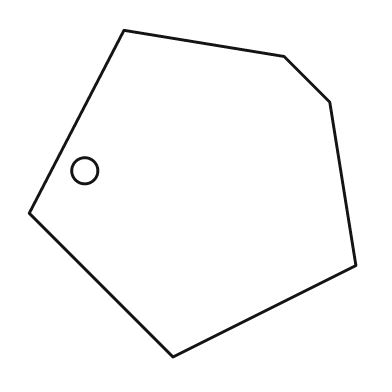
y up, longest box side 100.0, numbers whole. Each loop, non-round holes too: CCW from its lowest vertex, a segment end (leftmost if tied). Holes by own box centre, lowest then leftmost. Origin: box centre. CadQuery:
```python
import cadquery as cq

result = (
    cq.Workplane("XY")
    .moveTo(-6.0, -50.0)
    .lineTo(50.0, -22.0)
    .lineTo(42.0, 28.0)
    .lineTo(28.0, 42.0)
    .lineTo(-21.0, 50.0)
    .lineTo(-50.0, -6.0)
    .close()
    .moveTo(-33.0, 7.0)
    .circle(4.0)
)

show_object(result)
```